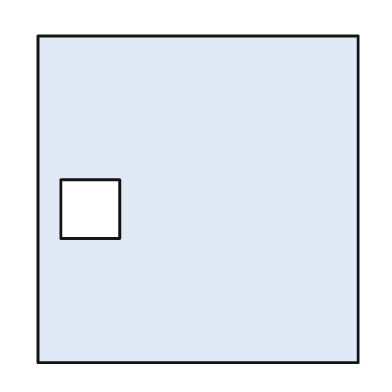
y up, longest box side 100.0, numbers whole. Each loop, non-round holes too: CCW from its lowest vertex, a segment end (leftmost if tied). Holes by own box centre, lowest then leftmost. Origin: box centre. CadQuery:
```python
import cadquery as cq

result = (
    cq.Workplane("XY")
    .moveTo(-49.0, -50.0)
    .lineTo(49.0, -50.0)
    .lineTo(49.0, 50.0)
    .lineTo(-49.0, 50.0)
    .close()
    .moveTo(-42.0, -12.0)
    .lineTo(-24.0, -12.0)
    .lineTo(-24.0, 6.0)
    .lineTo(-42.0, 6.0)
    .close()
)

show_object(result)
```